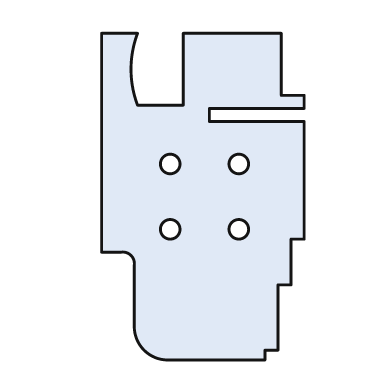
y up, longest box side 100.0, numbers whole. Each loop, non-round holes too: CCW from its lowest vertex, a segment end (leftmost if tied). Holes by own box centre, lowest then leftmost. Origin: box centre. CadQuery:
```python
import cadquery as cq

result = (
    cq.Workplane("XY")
    .moveTo(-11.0, -50.0)
    .lineTo(19.0, -50.0)
    .lineTo(19.0, -47.0)
    .lineTo(23.0, -47.0)
    .lineTo(23.0, -27.0)
    .lineTo(27.0, -27.0)
    .lineTo(27.0, -13.0)
    .lineTo(31.0, -13.0)
    .lineTo(31.0, 23.0)
    .lineTo(2.0, 23.0)
    .lineTo(2.0, 27.0)
    .lineTo(31.0, 27.0)
    .lineTo(31.0, 31.0)
    .lineTo(24.0, 31.0)
    .lineTo(24.0, 50.0)
    .lineTo(-6.0, 50.0)
    .lineTo(-6.0, 28.0)
    .lineTo(-20.0, 28.0)
    .threePointArc((-22.0, 39.0), (-20.0, 50.0))
    .lineTo(-31.0, 50.0)
    .lineTo(-31.0, -17.0)
    .lineTo(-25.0, -17.0)
    .threePointArc((-22.0, -18.0), (-21.0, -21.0))
    .lineTo(-21.0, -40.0)
    .threePointArc((-18.0, -47.0), (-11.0, -50.0))
    .close()
    .moveTo(-10.0, -10.0)
    .circle(3.0)
    .moveTo(11.0, -10.0)
    .circle(3.0)
    .moveTo(-10.0, 10.0)
    .circle(3.0)
    .moveTo(11.0, 10.0)
    .circle(3.0)
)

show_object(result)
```